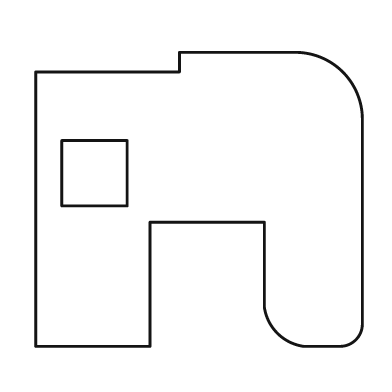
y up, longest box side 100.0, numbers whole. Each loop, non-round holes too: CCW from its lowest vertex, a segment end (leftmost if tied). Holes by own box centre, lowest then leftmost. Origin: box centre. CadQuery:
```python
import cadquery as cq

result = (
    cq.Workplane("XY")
    .moveTo(-50.0, -45.0)
    .lineTo(-15.0, -45.0)
    .lineTo(-15.0, -7.0)
    .lineTo(20.0, -7.0)
    .lineTo(20.0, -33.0)
    .threePointArc((24.0, -41.0), (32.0, -45.0))
    .lineTo(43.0, -45.0)
    .threePointArc((48.0, -43.0), (50.0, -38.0))
    .lineTo(50.0, 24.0)
    .threePointArc((44.0, 39.0), (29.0, 45.0))
    .lineTo(-6.0, 45.0)
    .lineTo(-6.0, 39.0)
    .lineTo(-50.0, 39.0)
    .close()
    .moveTo(-42.0, -2.0)
    .lineTo(-22.0, -2.0)
    .lineTo(-22.0, 18.0)
    .lineTo(-42.0, 18.0)
    .close()
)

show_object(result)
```